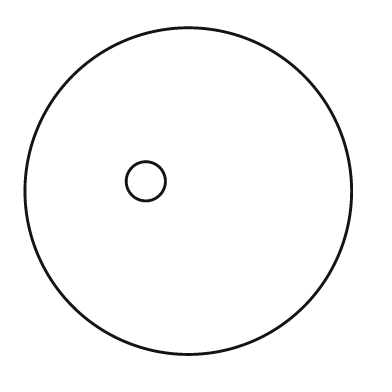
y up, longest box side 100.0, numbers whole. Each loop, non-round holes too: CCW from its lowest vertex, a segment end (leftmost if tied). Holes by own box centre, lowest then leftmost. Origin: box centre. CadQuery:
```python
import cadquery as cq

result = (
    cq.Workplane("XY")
    .moveTo(0.0, 0.0)
    .circle(50.0)
    .moveTo(-13.0, 3.0)
    .circle(6.0)
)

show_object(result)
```